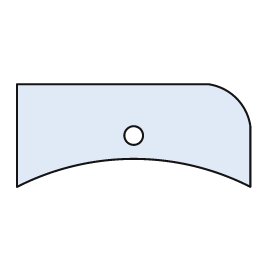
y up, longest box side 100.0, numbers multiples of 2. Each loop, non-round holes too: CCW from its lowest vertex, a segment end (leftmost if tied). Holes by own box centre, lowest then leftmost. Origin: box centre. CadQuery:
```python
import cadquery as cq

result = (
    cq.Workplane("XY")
    .moveTo(-50.0, -22.0)
    .threePointArc((0.0, -10.0), (50.0, -22.0))
    .lineTo(50.0, 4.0)
    .threePointArc((44.0, 16.0), (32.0, 22.0))
    .lineTo(-50.0, 22.0)
    .close()
    .moveTo(0.0, 0.0)
    .circle(4.0)
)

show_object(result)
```